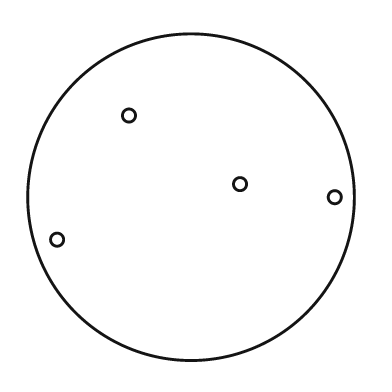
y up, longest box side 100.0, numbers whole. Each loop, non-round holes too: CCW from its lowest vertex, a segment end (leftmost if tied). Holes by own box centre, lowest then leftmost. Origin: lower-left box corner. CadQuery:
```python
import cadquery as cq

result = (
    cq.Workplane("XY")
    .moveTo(50.0, 50.0)
    .circle(50.0)
    .moveTo(9.0, 37.0)
    .circle(2.0)
    .moveTo(94.0, 50.0)
    .circle(2.0)
    .moveTo(65.0, 54.0)
    .circle(2.0)
    .moveTo(31.0, 75.0)
    .circle(2.0)
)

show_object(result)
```